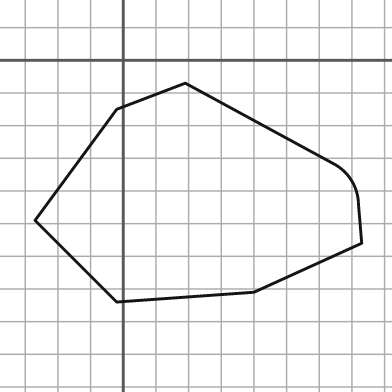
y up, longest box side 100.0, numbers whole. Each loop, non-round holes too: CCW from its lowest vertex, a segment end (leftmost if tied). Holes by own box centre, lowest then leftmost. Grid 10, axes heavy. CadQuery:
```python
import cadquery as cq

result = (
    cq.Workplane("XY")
    .moveTo(-2.0, -74.0)
    .lineTo(40.0, -71.0)
    .lineTo(73.0, -56.0)
    .lineTo(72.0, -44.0)
    .threePointArc((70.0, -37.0), (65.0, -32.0))
    .lineTo(19.0, -7.0)
    .lineTo(-2.0, -15.0)
    .lineTo(-27.0, -49.0)
    .close()
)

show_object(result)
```